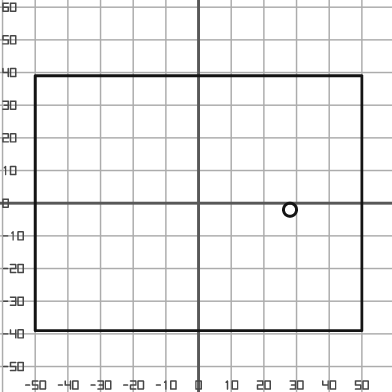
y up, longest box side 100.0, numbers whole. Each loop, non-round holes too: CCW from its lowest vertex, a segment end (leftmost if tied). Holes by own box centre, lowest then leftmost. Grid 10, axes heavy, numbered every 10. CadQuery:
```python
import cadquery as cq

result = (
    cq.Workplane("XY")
    .moveTo(-50.0, -39.0)
    .lineTo(50.0, -39.0)
    .lineTo(50.0, 39.0)
    .lineTo(-50.0, 39.0)
    .close()
    .moveTo(28.0, -2.0)
    .circle(2.0)
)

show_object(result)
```